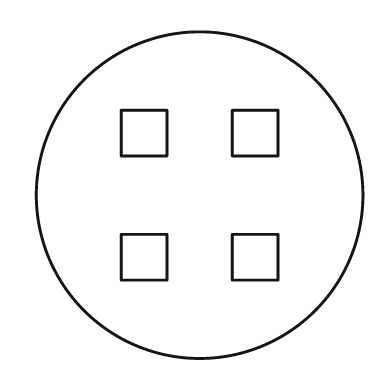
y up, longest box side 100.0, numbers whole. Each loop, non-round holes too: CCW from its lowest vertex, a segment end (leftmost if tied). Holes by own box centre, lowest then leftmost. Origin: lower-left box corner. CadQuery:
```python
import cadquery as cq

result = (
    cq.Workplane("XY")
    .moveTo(50.0, 50.0)
    .circle(50.0)
    .moveTo(26.0, 24.0)
    .lineTo(40.0, 24.0)
    .lineTo(40.0, 38.0)
    .lineTo(26.0, 38.0)
    .close()
    .moveTo(60.0, 24.0)
    .lineTo(74.0, 24.0)
    .lineTo(74.0, 38.0)
    .lineTo(60.0, 38.0)
    .close()
    .moveTo(26.0, 62.0)
    .lineTo(40.0, 62.0)
    .lineTo(40.0, 76.0)
    .lineTo(26.0, 76.0)
    .close()
    .moveTo(60.0, 62.0)
    .lineTo(74.0, 62.0)
    .lineTo(74.0, 76.0)
    .lineTo(60.0, 76.0)
    .close()
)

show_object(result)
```